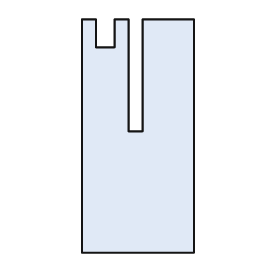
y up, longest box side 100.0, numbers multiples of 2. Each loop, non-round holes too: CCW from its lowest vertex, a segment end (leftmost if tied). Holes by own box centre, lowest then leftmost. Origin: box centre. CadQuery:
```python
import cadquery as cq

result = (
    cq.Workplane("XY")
    .moveTo(-24.0, -50.0)
    .lineTo(24.0, -50.0)
    .lineTo(24.0, 50.0)
    .lineTo(2.0, 50.0)
    .lineTo(2.0, 2.0)
    .lineTo(-4.0, 2.0)
    .lineTo(-4.0, 50.0)
    .lineTo(-10.0, 50.0)
    .lineTo(-10.0, 38.0)
    .lineTo(-18.0, 38.0)
    .lineTo(-18.0, 50.0)
    .lineTo(-24.0, 50.0)
    .close()
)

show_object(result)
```